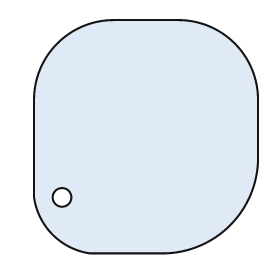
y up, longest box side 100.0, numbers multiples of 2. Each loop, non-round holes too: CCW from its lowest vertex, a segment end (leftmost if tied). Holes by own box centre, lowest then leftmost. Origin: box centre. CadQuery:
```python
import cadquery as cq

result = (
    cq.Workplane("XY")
    .moveTo(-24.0, -50.0)
    .lineTo(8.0, -50.0)
    .threePointArc((36.0, -38.0), (48.0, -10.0))
    .lineTo(48.0, 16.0)
    .threePointArc((38.0, 40.0), (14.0, 50.0))
    .lineTo(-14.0, 50.0)
    .threePointArc((-38.0, 40.0), (-48.0, 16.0))
    .lineTo(-48.0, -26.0)
    .threePointArc((-40.0, -42.0), (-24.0, -50.0))
    .close()
    .moveTo(-36.0, -26.0)
    .circle(4.0)
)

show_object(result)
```